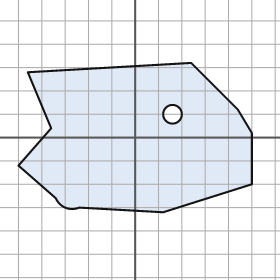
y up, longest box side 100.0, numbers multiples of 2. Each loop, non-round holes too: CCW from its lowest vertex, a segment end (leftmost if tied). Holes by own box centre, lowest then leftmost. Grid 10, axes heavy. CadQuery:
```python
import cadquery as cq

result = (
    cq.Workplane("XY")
    .moveTo(12.0, -32.0)
    .lineTo(50.0, -20.0)
    .lineTo(50.0, 2.0)
    .lineTo(44.0, 12.0)
    .lineTo(24.0, 32.0)
    .lineTo(-46.0, 28.0)
    .lineTo(-36.0, 4.0)
    .lineTo(-50.0, -12.0)
    .lineTo(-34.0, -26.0)
    .threePointArc((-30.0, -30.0), (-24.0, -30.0))
    .close()
    .moveTo(16.0, 10.0)
    .circle(4.0)
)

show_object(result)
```